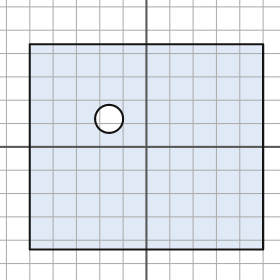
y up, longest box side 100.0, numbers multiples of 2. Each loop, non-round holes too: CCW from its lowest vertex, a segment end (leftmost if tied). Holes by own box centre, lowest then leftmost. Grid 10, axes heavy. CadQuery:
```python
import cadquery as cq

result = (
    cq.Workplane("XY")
    .moveTo(-50.0, -44.0)
    .lineTo(50.0, -44.0)
    .lineTo(50.0, 44.0)
    .lineTo(-50.0, 44.0)
    .close()
    .moveTo(-16.0, 12.0)
    .circle(6.0)
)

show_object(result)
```